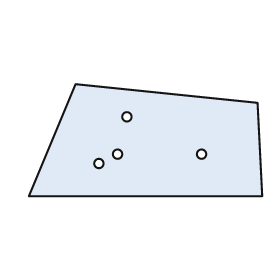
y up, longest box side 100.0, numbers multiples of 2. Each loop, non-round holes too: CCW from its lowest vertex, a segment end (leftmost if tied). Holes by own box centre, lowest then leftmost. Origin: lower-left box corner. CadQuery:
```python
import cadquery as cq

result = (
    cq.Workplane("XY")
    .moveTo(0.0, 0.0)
    .lineTo(100.0, 0.0)
    .lineTo(98.0, 40.0)
    .lineTo(20.0, 48.0)
    .close()
    .moveTo(30.0, 14.0)
    .circle(2.0)
    .moveTo(38.0, 18.0)
    .circle(2.0)
    .moveTo(74.0, 18.0)
    .circle(2.0)
    .moveTo(42.0, 34.0)
    .circle(2.0)
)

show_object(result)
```